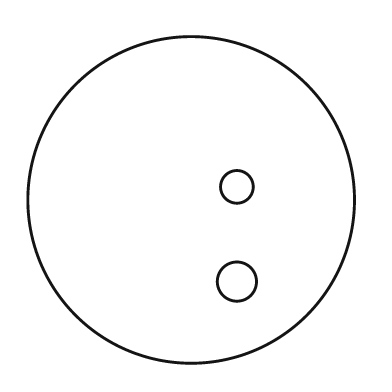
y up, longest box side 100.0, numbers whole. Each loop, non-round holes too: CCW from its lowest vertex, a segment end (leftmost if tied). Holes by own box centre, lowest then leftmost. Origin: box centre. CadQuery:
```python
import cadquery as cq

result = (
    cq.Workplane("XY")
    .moveTo(0.0, 0.0)
    .circle(50.0)
    .moveTo(14.0, -25.0)
    .circle(6.0)
    .moveTo(14.0, 4.0)
    .circle(5.0)
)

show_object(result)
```